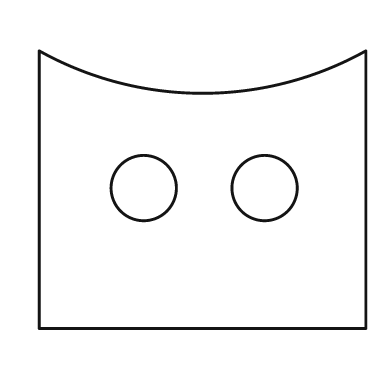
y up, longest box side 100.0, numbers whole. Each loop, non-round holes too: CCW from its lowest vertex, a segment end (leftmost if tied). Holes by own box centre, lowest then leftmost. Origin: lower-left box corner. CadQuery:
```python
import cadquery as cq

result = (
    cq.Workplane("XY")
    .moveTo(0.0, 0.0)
    .lineTo(100.0, 0.0)
    .lineTo(100.0, 85.0)
    .threePointArc((50.0, 72.0), (0.0, 85.0))
    .close()
    .moveTo(32.0, 43.0)
    .circle(10.0)
    .moveTo(69.0, 43.0)
    .circle(10.0)
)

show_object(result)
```